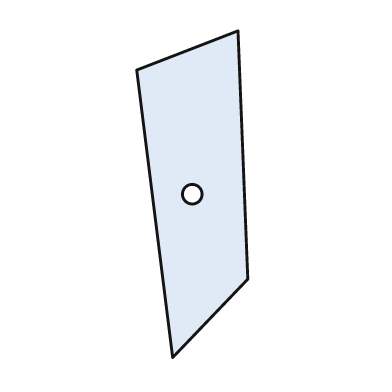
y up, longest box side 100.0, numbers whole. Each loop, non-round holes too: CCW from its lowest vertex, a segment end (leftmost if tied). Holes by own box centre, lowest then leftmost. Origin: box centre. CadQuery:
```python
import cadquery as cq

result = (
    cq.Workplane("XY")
    .moveTo(-6.0, -50.0)
    .lineTo(17.0, -26.0)
    .lineTo(14.0, 50.0)
    .lineTo(-17.0, 38.0)
    .close()
    .moveTo(0.0, 0.0)
    .circle(3.0)
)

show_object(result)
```